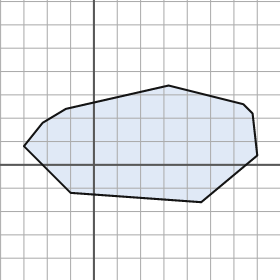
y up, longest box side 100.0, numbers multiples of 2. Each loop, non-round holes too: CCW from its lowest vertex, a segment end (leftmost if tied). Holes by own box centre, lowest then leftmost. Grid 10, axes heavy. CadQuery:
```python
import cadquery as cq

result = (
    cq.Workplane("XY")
    .moveTo(46.0, -16.0)
    .lineTo(70.0, 4.0)
    .lineTo(68.0, 22.0)
    .lineTo(64.0, 26.0)
    .lineTo(32.0, 34.0)
    .lineTo(-12.0, 24.0)
    .lineTo(-22.0, 18.0)
    .lineTo(-30.0, 8.0)
    .lineTo(-10.0, -12.0)
    .close()
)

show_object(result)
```